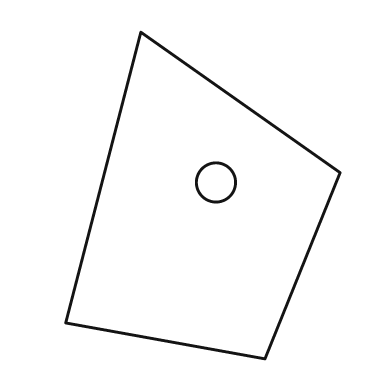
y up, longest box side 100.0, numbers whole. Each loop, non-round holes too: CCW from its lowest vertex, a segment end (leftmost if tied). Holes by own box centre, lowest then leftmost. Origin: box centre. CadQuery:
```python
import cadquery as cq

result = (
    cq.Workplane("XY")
    .moveTo(19.0, -50.0)
    .lineTo(42.0, 7.0)
    .lineTo(-19.0, 50.0)
    .lineTo(-42.0, -39.0)
    .close()
    .moveTo(4.0, 4.0)
    .circle(6.0)
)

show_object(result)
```